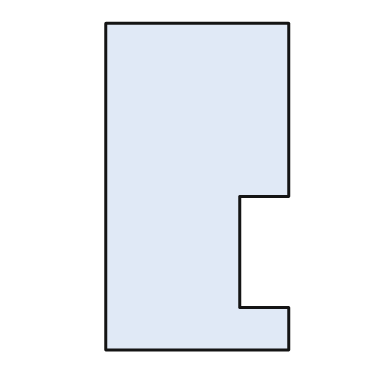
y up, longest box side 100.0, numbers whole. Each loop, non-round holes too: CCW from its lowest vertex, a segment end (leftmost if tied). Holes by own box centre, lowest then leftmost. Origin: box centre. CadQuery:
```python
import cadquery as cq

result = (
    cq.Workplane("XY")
    .moveTo(-28.0, -50.0)
    .lineTo(28.0, -50.0)
    .lineTo(28.0, -37.0)
    .lineTo(13.0, -37.0)
    .lineTo(13.0, -3.0)
    .lineTo(28.0, -3.0)
    .lineTo(28.0, 50.0)
    .lineTo(-28.0, 50.0)
    .close()
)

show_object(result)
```